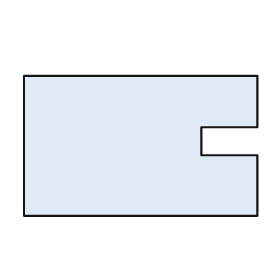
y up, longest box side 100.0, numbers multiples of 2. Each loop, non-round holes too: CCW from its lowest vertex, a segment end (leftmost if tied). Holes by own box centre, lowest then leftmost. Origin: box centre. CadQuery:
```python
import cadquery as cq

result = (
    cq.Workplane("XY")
    .moveTo(-50.0, -30.0)
    .lineTo(50.0, -30.0)
    .lineTo(50.0, -4.0)
    .lineTo(26.0, -4.0)
    .lineTo(26.0, 8.0)
    .lineTo(50.0, 8.0)
    .lineTo(50.0, 30.0)
    .lineTo(-50.0, 30.0)
    .close()
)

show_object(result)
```